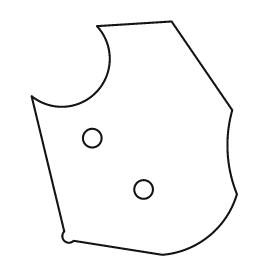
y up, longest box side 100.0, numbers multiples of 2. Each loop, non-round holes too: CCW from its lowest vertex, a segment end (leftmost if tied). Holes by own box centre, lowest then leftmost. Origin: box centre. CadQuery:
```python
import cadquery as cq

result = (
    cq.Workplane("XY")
    .moveTo(12.0, -50.0)
    .threePointArc((32.0, -42.0), (44.0, -24.0))
    .threePointArc((40.0, -6.0), (42.0, 12.0))
    .lineTo(16.0, 50.0)
    .lineTo(-16.0, 48.0)
    .threePointArc((-16.0, 20.0), (-44.0, 18.0))
    .lineTo(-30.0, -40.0)
    .threePointArc((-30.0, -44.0), (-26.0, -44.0))
    .close()
    .moveTo(4.0, -22.0)
    .circle(4.0)
    .moveTo(-18.0, 0.0)
    .circle(4.0)
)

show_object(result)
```